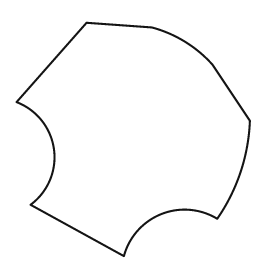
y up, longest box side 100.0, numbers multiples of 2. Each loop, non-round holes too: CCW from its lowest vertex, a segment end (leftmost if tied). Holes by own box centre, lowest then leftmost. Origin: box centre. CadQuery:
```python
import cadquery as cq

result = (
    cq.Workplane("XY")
    .moveTo(-4.0, -50.0)
    .threePointArc((12.0, -32.0), (36.0, -34.0))
    .threePointArc((46.0, -14.0), (50.0, 8.0))
    .lineTo(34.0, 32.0)
    .threePointArc((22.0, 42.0), (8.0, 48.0))
    .lineTo(-20.0, 50.0)
    .lineTo(-50.0, 16.0)
    .threePointArc((-34.0, -4.0), (-44.0, -28.0))
    .close()
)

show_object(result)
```